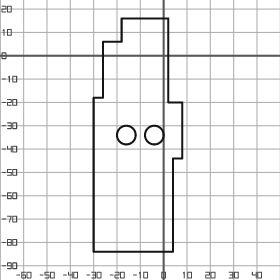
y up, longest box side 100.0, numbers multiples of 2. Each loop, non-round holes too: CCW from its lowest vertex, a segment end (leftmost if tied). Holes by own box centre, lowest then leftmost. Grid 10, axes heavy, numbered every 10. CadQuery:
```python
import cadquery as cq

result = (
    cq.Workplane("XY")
    .moveTo(-30.0, -84.0)
    .lineTo(4.0, -84.0)
    .lineTo(4.0, -44.0)
    .lineTo(8.0, -44.0)
    .lineTo(8.0, -20.0)
    .lineTo(2.0, -20.0)
    .lineTo(2.0, 16.0)
    .lineTo(-18.0, 16.0)
    .lineTo(-18.0, 6.0)
    .lineTo(-26.0, 6.0)
    .lineTo(-26.0, -18.0)
    .lineTo(-30.0, -18.0)
    .close()
    .moveTo(-16.0, -34.0)
    .circle(4.0)
    .moveTo(-4.0, -34.0)
    .circle(4.0)
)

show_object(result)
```